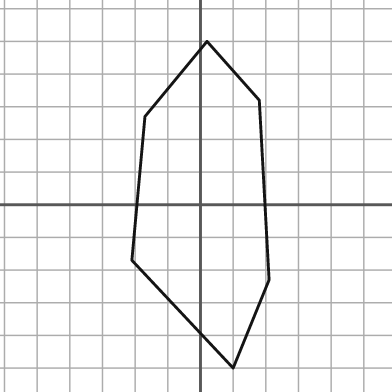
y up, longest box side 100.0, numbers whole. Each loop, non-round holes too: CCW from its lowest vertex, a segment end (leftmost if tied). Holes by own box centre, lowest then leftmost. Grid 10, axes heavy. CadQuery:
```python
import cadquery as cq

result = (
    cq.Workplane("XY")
    .moveTo(10.0, -50.0)
    .lineTo(21.0, -23.0)
    .lineTo(18.0, 32.0)
    .lineTo(2.0, 50.0)
    .lineTo(-17.0, 27.0)
    .lineTo(-21.0, -17.0)
    .close()
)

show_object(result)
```